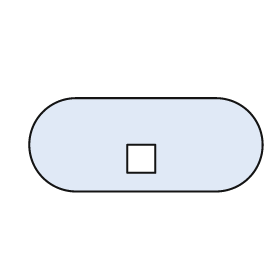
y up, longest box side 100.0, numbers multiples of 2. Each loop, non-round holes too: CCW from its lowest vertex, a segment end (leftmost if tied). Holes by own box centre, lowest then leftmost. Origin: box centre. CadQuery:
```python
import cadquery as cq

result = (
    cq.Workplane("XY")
    .moveTo(-30.0, -20.0)
    .lineTo(30.0, -20.0)
    .threePointArc((50.0, 0.0), (30.0, 20.0))
    .lineTo(-30.0, 20.0)
    .threePointArc((-50.0, 0.0), (-30.0, -20.0))
    .close()
    .moveTo(-8.0, -12.0)
    .lineTo(4.0, -12.0)
    .lineTo(4.0, 0.0)
    .lineTo(-8.0, 0.0)
    .close()
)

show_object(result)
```